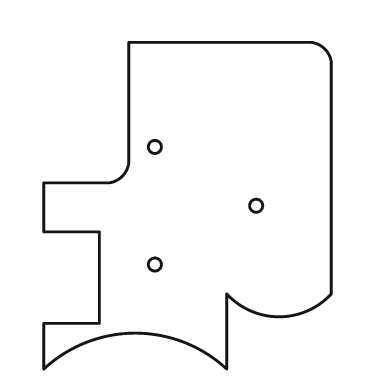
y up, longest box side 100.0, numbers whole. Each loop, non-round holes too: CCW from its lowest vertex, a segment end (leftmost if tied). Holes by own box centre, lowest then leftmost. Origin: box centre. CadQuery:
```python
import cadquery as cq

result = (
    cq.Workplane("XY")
    .moveTo(-44.0, -50.0)
    .threePointArc((-16.0, -39.0), (12.0, -50.0))
    .lineTo(12.0, -27.0)
    .threePointArc((28.0, -34.0), (44.0, -27.0))
    .lineTo(44.0, 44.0)
    .threePointArc((42.0, 48.0), (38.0, 50.0))
    .lineTo(-18.0, 50.0)
    .lineTo(-18.0, 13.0)
    .threePointArc((-20.0, 9.0), (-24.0, 7.0))
    .lineTo(-44.0, 7.0)
    .lineTo(-44.0, -8.0)
    .lineTo(-27.0, -8.0)
    .lineTo(-27.0, -36.0)
    .lineTo(-44.0, -36.0)
    .close()
    .moveTo(-10.0, -18.0)
    .circle(2.0)
    .moveTo(21.0, 0.0)
    .circle(2.0)
    .moveTo(-10.0, 18.0)
    .circle(2.0)
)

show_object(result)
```